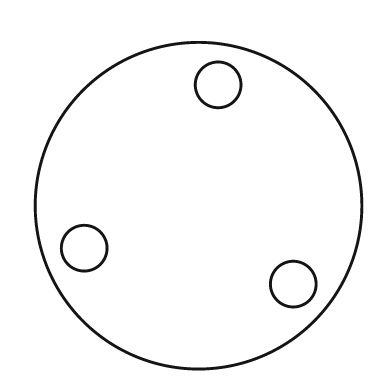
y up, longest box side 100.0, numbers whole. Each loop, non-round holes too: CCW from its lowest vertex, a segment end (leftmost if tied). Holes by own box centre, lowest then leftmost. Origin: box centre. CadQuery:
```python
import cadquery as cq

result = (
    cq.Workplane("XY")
    .moveTo(0.0, 0.0)
    .circle(50.0)
    .moveTo(29.0, -24.0)
    .circle(7.0)
    .moveTo(-35.0, -13.0)
    .circle(7.0)
    .moveTo(6.0, 37.0)
    .circle(7.0)
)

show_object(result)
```